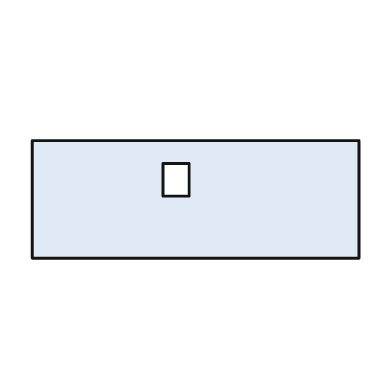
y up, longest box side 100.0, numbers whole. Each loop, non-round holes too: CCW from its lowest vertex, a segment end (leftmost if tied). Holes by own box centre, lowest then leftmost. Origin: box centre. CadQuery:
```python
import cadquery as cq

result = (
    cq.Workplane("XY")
    .moveTo(-50.0, -18.0)
    .lineTo(50.0, -18.0)
    .lineTo(50.0, 18.0)
    .lineTo(-50.0, 18.0)
    .close()
    .moveTo(-10.0, 1.0)
    .lineTo(-2.0, 1.0)
    .lineTo(-2.0, 11.0)
    .lineTo(-10.0, 11.0)
    .close()
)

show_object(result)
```